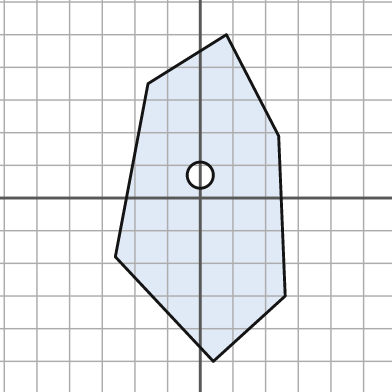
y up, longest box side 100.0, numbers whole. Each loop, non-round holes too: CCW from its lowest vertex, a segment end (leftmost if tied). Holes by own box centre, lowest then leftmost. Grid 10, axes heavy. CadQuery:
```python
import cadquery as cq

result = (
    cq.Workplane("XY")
    .moveTo(4.0, -50.0)
    .lineTo(26.0, -30.0)
    .lineTo(24.0, 19.0)
    .lineTo(8.0, 50.0)
    .lineTo(-16.0, 35.0)
    .lineTo(-26.0, -18.0)
    .close()
    .moveTo(0.0, 7.0)
    .circle(4.0)
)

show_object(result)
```